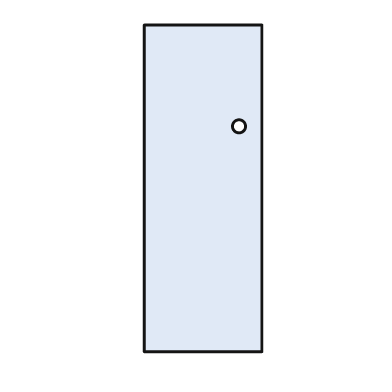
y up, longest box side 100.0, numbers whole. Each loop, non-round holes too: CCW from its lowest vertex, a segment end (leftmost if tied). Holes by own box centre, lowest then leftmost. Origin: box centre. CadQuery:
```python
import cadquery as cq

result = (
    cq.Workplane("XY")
    .moveTo(-18.0, -50.0)
    .lineTo(18.0, -50.0)
    .lineTo(18.0, 50.0)
    .lineTo(-18.0, 50.0)
    .close()
    .moveTo(11.0, 19.0)
    .circle(2.0)
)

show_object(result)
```